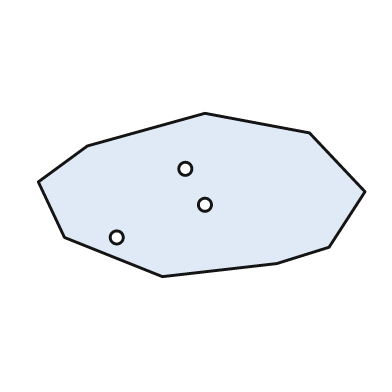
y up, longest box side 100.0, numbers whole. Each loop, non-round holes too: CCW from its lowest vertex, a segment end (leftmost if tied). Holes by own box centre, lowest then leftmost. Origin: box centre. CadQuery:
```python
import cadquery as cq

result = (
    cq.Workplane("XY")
    .moveTo(-12.0, -25.0)
    .lineTo(23.0, -21.0)
    .lineTo(39.0, -16.0)
    .lineTo(50.0, 1.0)
    .lineTo(33.0, 19.0)
    .lineTo(1.0, 25.0)
    .lineTo(-35.0, 15.0)
    .lineTo(-50.0, 4.0)
    .lineTo(-42.0, -13.0)
    .close()
    .moveTo(-26.0, -13.0)
    .circle(2.0)
    .moveTo(1.0, -3.0)
    .circle(2.0)
    .moveTo(-5.0, 8.0)
    .circle(2.0)
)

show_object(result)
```